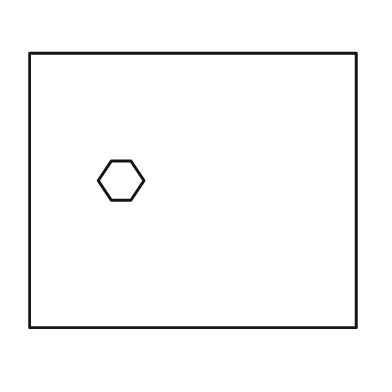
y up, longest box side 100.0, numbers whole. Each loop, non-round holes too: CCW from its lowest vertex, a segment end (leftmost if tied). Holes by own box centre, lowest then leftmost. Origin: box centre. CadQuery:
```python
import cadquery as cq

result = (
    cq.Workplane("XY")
    .moveTo(-50.0, -42.0)
    .lineTo(50.0, -42.0)
    .lineTo(50.0, 42.0)
    .lineTo(-50.0, 42.0)
    .close()
    .moveTo(-25.0, -3.0)
    .lineTo(-19.0, -3.0)
    .lineTo(-15.0, 3.0)
    .lineTo(-19.0, 9.0)
    .lineTo(-25.0, 9.0)
    .lineTo(-29.0, 3.0)
    .close()
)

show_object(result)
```